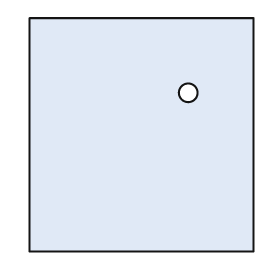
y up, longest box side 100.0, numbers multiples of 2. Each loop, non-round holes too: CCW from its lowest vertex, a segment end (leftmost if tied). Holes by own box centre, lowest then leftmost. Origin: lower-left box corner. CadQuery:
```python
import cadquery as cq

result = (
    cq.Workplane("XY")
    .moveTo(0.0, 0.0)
    .lineTo(96.0, 0.0)
    .lineTo(96.0, 100.0)
    .lineTo(0.0, 100.0)
    .close()
    .moveTo(68.0, 68.0)
    .circle(4.0)
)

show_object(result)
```